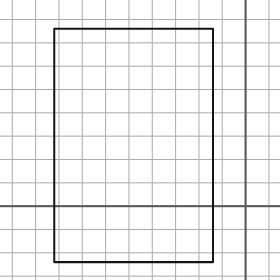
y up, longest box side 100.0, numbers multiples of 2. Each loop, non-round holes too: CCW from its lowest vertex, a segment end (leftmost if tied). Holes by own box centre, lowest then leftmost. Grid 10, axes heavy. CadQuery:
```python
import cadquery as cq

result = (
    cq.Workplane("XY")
    .moveTo(-82.0, -24.0)
    .lineTo(-14.0, -24.0)
    .lineTo(-14.0, 76.0)
    .lineTo(-82.0, 76.0)
    .close()
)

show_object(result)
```